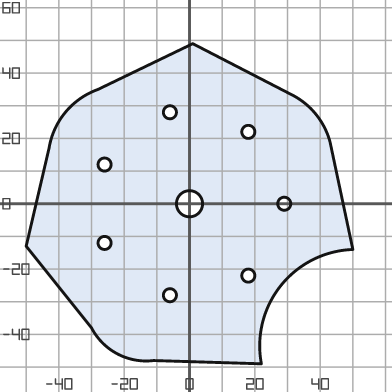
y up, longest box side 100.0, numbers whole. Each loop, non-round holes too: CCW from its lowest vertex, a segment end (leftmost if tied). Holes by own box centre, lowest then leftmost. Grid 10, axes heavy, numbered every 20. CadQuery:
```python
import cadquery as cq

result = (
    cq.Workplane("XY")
    .moveTo(22.0, -49.0)
    .threePointArc((28.0, -25.0), (50.0, -14.0))
    .lineTo(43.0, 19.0)
    .threePointArc((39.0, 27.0), (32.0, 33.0))
    .lineTo(1.0, 49.0)
    .lineTo(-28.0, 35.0)
    .threePointArc((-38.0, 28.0), (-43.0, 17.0))
    .lineTo(-50.0, -13.0)
    .lineTo(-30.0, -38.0)
    .threePointArc((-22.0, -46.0), (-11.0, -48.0))
    .close()
    .moveTo(-6.0, -28.0)
    .circle(2.0)
    .moveTo(18.0, -22.0)
    .circle(2.0)
    .moveTo(-26.0, -12.0)
    .circle(2.0)
    .moveTo(0.0, 0.0)
    .circle(4.0)
    .moveTo(29.0, 0.0)
    .circle(2.0)
    .moveTo(-26.0, 12.0)
    .circle(2.0)
    .moveTo(18.0, 22.0)
    .circle(2.0)
    .moveTo(-6.0, 28.0)
    .circle(2.0)
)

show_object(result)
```